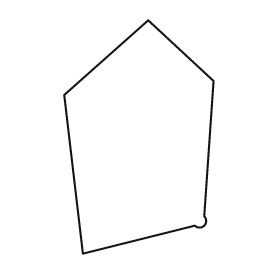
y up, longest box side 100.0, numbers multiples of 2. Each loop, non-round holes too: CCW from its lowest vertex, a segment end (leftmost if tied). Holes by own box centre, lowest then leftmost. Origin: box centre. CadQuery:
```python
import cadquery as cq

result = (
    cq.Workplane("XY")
    .moveTo(-24.0, -50.0)
    .lineTo(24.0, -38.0)
    .threePointArc((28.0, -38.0), (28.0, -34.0))
    .lineTo(32.0, 24.0)
    .lineTo(4.0, 50.0)
    .lineTo(-32.0, 18.0)
    .close()
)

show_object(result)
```